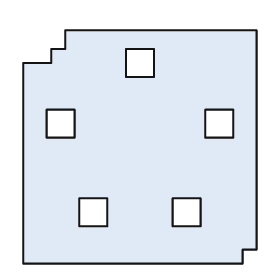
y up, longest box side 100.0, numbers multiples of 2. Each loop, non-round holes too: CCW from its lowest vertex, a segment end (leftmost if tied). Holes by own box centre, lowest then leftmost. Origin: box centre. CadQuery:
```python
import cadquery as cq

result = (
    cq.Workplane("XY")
    .moveTo(-50.0, -50.0)
    .lineTo(44.0, -50.0)
    .lineTo(44.0, -44.0)
    .lineTo(50.0, -44.0)
    .lineTo(50.0, 50.0)
    .lineTo(-32.0, 50.0)
    .lineTo(-32.0, 42.0)
    .lineTo(-38.0, 42.0)
    .lineTo(-38.0, 36.0)
    .lineTo(-50.0, 36.0)
    .close()
    .moveTo(-26.0, -34.0)
    .lineTo(-14.0, -34.0)
    .lineTo(-14.0, -22.0)
    .lineTo(-26.0, -22.0)
    .close()
    .moveTo(14.0, -34.0)
    .lineTo(26.0, -34.0)
    .lineTo(26.0, -22.0)
    .lineTo(14.0, -22.0)
    .close()
    .moveTo(-40.0, 4.0)
    .lineTo(-28.0, 4.0)
    .lineTo(-28.0, 16.0)
    .lineTo(-40.0, 16.0)
    .close()
    .moveTo(28.0, 4.0)
    .lineTo(40.0, 4.0)
    .lineTo(40.0, 16.0)
    .lineTo(28.0, 16.0)
    .close()
    .moveTo(-6.0, 30.0)
    .lineTo(6.0, 30.0)
    .lineTo(6.0, 42.0)
    .lineTo(-6.0, 42.0)
    .close()
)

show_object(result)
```